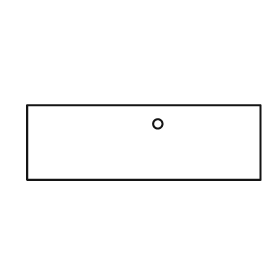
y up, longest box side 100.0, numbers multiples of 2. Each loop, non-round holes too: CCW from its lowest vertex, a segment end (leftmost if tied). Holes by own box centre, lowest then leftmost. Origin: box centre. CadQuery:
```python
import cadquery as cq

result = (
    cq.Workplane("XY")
    .moveTo(-50.0, -16.0)
    .lineTo(50.0, -16.0)
    .lineTo(50.0, 16.0)
    .lineTo(-50.0, 16.0)
    .close()
    .moveTo(6.0, 8.0)
    .circle(2.0)
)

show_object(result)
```